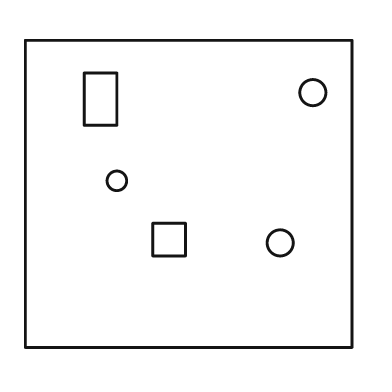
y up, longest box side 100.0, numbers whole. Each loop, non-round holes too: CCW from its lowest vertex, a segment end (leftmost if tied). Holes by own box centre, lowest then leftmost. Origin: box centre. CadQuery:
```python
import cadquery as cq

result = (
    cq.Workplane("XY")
    .moveTo(-50.0, -47.0)
    .lineTo(50.0, -47.0)
    .lineTo(50.0, 47.0)
    .lineTo(-50.0, 47.0)
    .close()
    .moveTo(28.0, -15.0)
    .circle(4.0)
    .moveTo(-11.0, -19.0)
    .lineTo(-1.0, -19.0)
    .lineTo(-1.0, -9.0)
    .lineTo(-11.0, -9.0)
    .close()
    .moveTo(-22.0, 4.0)
    .circle(3.0)
    .moveTo(-32.0, 21.0)
    .lineTo(-22.0, 21.0)
    .lineTo(-22.0, 37.0)
    .lineTo(-32.0, 37.0)
    .close()
    .moveTo(38.0, 31.0)
    .circle(4.0)
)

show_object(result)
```